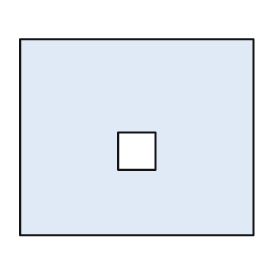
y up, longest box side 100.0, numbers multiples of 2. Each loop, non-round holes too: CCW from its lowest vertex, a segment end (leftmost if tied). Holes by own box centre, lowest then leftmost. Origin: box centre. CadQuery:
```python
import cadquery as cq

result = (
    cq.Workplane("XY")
    .moveTo(-50.0, -42.0)
    .lineTo(50.0, -42.0)
    .lineTo(50.0, 42.0)
    .lineTo(-50.0, 42.0)
    .close()
    .moveTo(-8.0, -14.0)
    .lineTo(8.0, -14.0)
    .lineTo(8.0, 2.0)
    .lineTo(-8.0, 2.0)
    .close()
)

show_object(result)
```